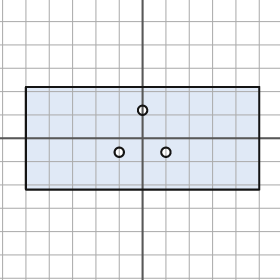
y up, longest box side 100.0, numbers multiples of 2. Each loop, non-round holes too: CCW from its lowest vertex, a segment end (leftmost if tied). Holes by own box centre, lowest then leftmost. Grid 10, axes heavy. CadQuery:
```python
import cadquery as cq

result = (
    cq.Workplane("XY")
    .moveTo(-50.0, -22.0)
    .lineTo(50.0, -22.0)
    .lineTo(50.0, 22.0)
    .lineTo(-50.0, 22.0)
    .close()
    .moveTo(-10.0, -6.0)
    .circle(2.0)
    .moveTo(10.0, -6.0)
    .circle(2.0)
    .moveTo(0.0, 12.0)
    .circle(2.0)
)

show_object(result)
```